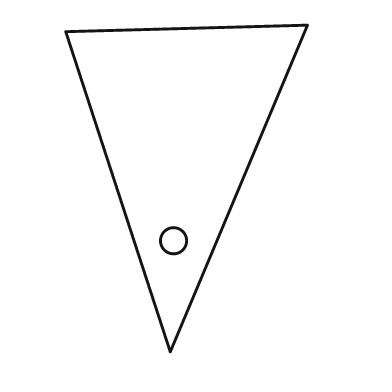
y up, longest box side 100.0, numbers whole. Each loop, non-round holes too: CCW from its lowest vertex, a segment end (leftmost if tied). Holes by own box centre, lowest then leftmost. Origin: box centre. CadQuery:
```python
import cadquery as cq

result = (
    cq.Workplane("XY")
    .moveTo(-5.0, -50.0)
    .lineTo(37.0, 50.0)
    .lineTo(-37.0, 48.0)
    .close()
    .moveTo(-4.0, -16.0)
    .circle(4.0)
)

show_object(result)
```